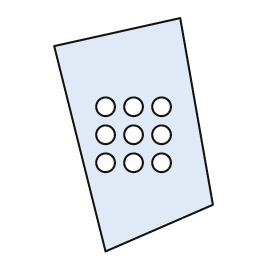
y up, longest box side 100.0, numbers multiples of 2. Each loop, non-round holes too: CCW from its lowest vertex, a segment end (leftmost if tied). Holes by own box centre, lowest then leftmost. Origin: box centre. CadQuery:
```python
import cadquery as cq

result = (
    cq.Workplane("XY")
    .moveTo(-12.0, -50.0)
    .lineTo(34.0, -30.0)
    .lineTo(20.0, 50.0)
    .lineTo(-34.0, 38.0)
    .close()
    .moveTo(-12.0, -12.0)
    .circle(4.0)
    .moveTo(0.0, -12.0)
    .circle(4.0)
    .moveTo(12.0, -12.0)
    .circle(4.0)
    .moveTo(-12.0, 0.0)
    .circle(4.0)
    .moveTo(0.0, 0.0)
    .circle(4.0)
    .moveTo(12.0, 0.0)
    .circle(4.0)
    .moveTo(-12.0, 12.0)
    .circle(4.0)
    .moveTo(0.0, 12.0)
    .circle(4.0)
    .moveTo(12.0, 12.0)
    .circle(4.0)
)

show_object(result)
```